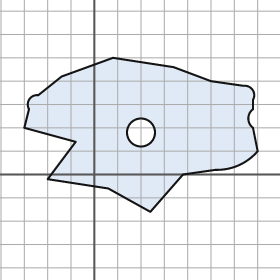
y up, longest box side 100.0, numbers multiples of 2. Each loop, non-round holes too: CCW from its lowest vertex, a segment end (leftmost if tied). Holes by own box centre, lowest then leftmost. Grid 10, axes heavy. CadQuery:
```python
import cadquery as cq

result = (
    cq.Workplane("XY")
    .moveTo(24.0, -16.0)
    .lineTo(38.0, 0.0)
    .lineTo(52.0, 2.0)
    .threePointArc((62.0, 4.0), (70.0, 10.0))
    .lineTo(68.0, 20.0)
    .threePointArc((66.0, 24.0), (68.0, 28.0))
    .lineTo(68.0, 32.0)
    .threePointArc((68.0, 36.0), (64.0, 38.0))
    .lineTo(50.0, 40.0)
    .lineTo(34.0, 46.0)
    .lineTo(8.0, 50.0)
    .lineTo(-14.0, 42.0)
    .lineTo(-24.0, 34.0)
    .threePointArc((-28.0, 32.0), (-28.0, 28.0))
    .lineTo(-30.0, 20.0)
    .lineTo(-8.0, 14.0)
    .lineTo(-20.0, -2.0)
    .lineTo(6.0, -6.0)
    .close()
    .moveTo(20.0, 18.0)
    .circle(6.0)
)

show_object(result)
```